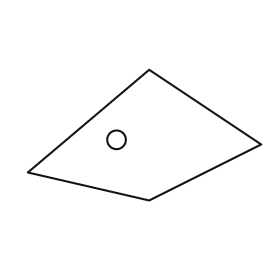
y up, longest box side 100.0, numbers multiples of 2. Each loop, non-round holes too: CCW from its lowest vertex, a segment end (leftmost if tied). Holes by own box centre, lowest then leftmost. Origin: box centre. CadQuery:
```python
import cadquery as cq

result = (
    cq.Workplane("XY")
    .moveTo(2.0, -28.0)
    .lineTo(50.0, -4.0)
    .lineTo(2.0, 28.0)
    .lineTo(-50.0, -16.0)
    .close()
    .moveTo(-12.0, -2.0)
    .circle(4.0)
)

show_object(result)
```